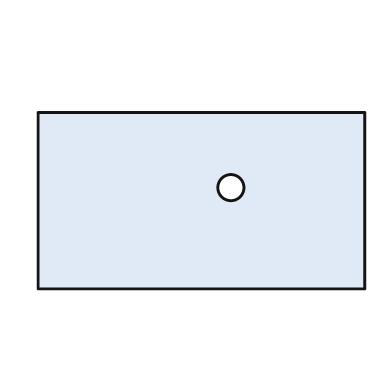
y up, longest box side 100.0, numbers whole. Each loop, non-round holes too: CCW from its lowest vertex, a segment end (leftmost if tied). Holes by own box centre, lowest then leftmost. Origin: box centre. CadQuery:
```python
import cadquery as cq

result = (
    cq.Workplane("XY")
    .moveTo(-50.0, -27.0)
    .lineTo(50.0, -27.0)
    .lineTo(50.0, 27.0)
    .lineTo(-50.0, 27.0)
    .close()
    .moveTo(9.0, 4.0)
    .circle(4.0)
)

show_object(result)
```